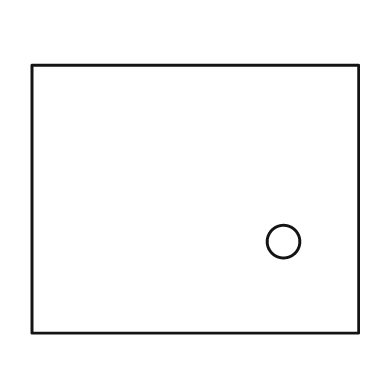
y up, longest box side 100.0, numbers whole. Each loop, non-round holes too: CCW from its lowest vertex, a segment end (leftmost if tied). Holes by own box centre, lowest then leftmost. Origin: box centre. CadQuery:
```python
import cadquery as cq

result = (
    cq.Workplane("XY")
    .moveTo(-50.0, -41.0)
    .lineTo(50.0, -41.0)
    .lineTo(50.0, 41.0)
    .lineTo(-50.0, 41.0)
    .close()
    .moveTo(27.0, -13.0)
    .circle(5.0)
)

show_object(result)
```